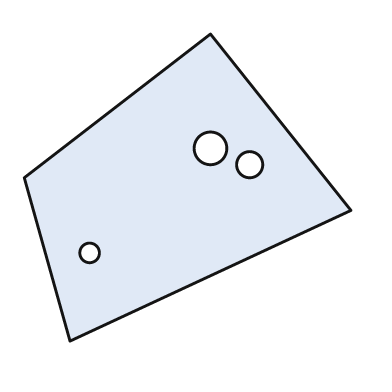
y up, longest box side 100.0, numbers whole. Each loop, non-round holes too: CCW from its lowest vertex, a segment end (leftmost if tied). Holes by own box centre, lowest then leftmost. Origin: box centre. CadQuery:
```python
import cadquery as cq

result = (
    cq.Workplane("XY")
    .moveTo(-36.0, -47.0)
    .lineTo(50.0, -7.0)
    .lineTo(7.0, 47.0)
    .lineTo(-50.0, 3.0)
    .close()
    .moveTo(-30.0, -20.0)
    .circle(3.0)
    .moveTo(19.0, 7.0)
    .circle(4.0)
    .moveTo(7.0, 12.0)
    .circle(5.0)
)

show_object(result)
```